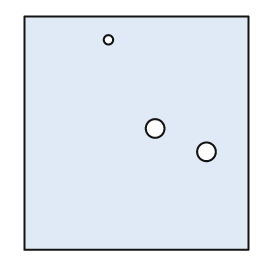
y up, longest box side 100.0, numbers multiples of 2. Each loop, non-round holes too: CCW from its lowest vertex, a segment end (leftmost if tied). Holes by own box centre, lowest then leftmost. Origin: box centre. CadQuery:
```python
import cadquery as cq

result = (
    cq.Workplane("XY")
    .moveTo(-48.0, -50.0)
    .lineTo(48.0, -50.0)
    .lineTo(48.0, 50.0)
    .lineTo(-48.0, 50.0)
    .close()
    .moveTo(30.0, -8.0)
    .circle(4.0)
    .moveTo(8.0, 2.0)
    .circle(4.0)
    .moveTo(-12.0, 40.0)
    .circle(2.0)
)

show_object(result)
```